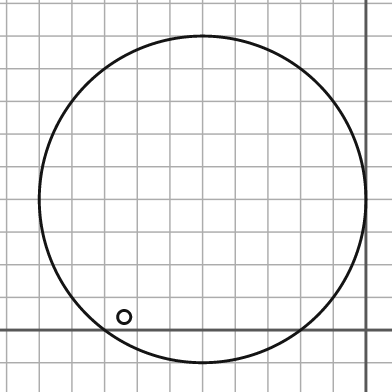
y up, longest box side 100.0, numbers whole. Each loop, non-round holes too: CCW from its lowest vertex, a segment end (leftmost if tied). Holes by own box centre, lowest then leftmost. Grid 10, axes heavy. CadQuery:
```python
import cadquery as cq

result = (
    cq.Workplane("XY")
    .moveTo(-50.0, 40.0)
    .circle(50.0)
    .moveTo(-74.0, 4.0)
    .circle(2.0)
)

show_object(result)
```